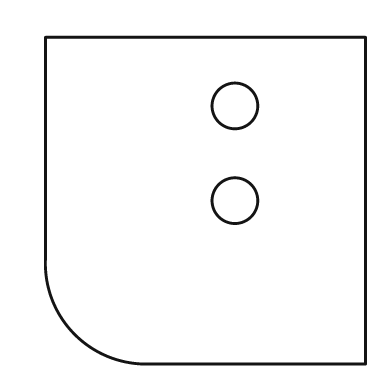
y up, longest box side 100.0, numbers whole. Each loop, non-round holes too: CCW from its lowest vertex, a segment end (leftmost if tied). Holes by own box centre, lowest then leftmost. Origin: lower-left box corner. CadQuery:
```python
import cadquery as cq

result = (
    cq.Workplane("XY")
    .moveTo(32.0, 0.0)
    .lineTo(98.0, 0.0)
    .lineTo(98.0, 100.0)
    .lineTo(0.0, 100.0)
    .lineTo(0.0, 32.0)
    .threePointArc((9.0, 9.0), (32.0, 0.0))
    .close()
    .moveTo(58.0, 50.0)
    .circle(7.0)
    .moveTo(58.0, 79.0)
    .circle(7.0)
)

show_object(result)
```